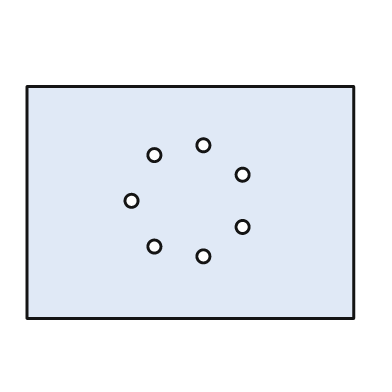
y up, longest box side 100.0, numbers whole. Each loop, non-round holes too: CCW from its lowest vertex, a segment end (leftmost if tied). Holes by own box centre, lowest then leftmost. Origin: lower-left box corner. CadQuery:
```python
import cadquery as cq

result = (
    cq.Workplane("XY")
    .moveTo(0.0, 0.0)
    .lineTo(100.0, 0.0)
    .lineTo(100.0, 71.0)
    .lineTo(0.0, 71.0)
    .close()
    .moveTo(54.0, 19.0)
    .circle(2.0)
    .moveTo(39.0, 22.0)
    .circle(2.0)
    .moveTo(66.0, 28.0)
    .circle(2.0)
    .moveTo(32.0, 36.0)
    .circle(2.0)
    .moveTo(66.0, 44.0)
    .circle(2.0)
    .moveTo(39.0, 50.0)
    .circle(2.0)
    .moveTo(54.0, 53.0)
    .circle(2.0)
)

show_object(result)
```